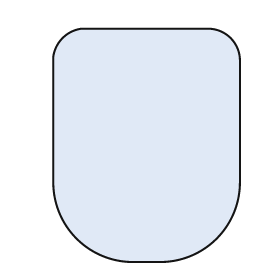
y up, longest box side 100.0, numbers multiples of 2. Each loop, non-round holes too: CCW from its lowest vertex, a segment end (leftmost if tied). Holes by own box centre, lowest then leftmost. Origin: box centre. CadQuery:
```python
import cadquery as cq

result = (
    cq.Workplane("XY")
    .moveTo(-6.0, -50.0)
    .lineTo(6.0, -50.0)
    .threePointArc((30.0, -40.0), (40.0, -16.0))
    .lineTo(40.0, 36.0)
    .threePointArc((36.0, 46.0), (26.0, 50.0))
    .lineTo(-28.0, 50.0)
    .threePointArc((-36.0, 46.0), (-40.0, 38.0))
    .lineTo(-40.0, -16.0)
    .threePointArc((-30.0, -40.0), (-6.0, -50.0))
    .close()
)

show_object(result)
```